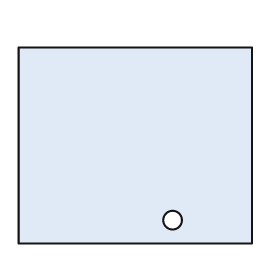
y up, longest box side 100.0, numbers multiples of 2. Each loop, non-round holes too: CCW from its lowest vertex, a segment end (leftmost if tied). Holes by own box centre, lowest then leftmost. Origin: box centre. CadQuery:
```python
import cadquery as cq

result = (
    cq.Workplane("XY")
    .moveTo(-50.0, -42.0)
    .lineTo(50.0, -42.0)
    .lineTo(50.0, 42.0)
    .lineTo(-50.0, 42.0)
    .close()
    .moveTo(16.0, -32.0)
    .circle(4.0)
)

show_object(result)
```